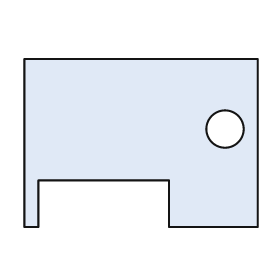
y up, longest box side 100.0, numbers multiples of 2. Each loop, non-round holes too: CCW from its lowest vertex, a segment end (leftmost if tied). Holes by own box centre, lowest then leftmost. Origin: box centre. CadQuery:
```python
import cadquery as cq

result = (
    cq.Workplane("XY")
    .moveTo(-50.0, -36.0)
    .lineTo(-44.0, -36.0)
    .lineTo(-44.0, -16.0)
    .lineTo(12.0, -16.0)
    .lineTo(12.0, -36.0)
    .lineTo(50.0, -36.0)
    .lineTo(50.0, 36.0)
    .lineTo(-50.0, 36.0)
    .close()
    .moveTo(36.0, 6.0)
    .circle(8.0)
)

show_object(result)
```